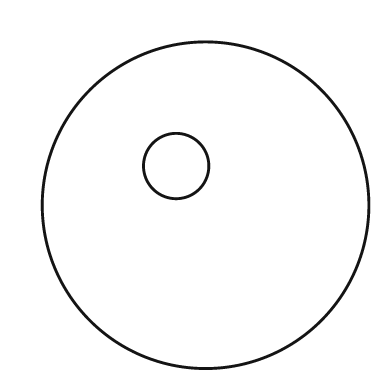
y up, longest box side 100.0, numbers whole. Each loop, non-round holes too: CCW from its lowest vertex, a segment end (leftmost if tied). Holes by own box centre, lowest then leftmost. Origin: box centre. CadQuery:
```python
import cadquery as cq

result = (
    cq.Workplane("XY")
    .moveTo(0.0, 0.0)
    .circle(50.0)
    .moveTo(-9.0, 12.0)
    .circle(10.0)
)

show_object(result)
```